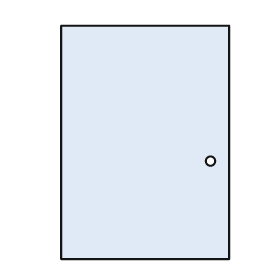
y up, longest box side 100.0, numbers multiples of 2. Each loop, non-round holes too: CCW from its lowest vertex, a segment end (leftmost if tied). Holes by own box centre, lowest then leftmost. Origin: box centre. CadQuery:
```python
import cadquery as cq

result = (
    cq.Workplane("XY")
    .moveTo(-36.0, -50.0)
    .lineTo(36.0, -50.0)
    .lineTo(36.0, 50.0)
    .lineTo(-36.0, 50.0)
    .close()
    .moveTo(28.0, -8.0)
    .circle(2.0)
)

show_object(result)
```